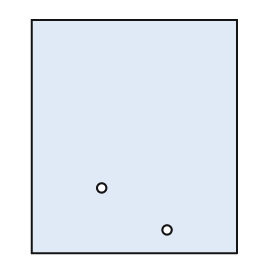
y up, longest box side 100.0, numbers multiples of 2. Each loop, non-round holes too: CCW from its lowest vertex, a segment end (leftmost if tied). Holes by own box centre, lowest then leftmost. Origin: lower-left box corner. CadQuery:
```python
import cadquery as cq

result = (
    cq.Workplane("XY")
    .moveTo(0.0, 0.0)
    .lineTo(88.0, 0.0)
    .lineTo(88.0, 100.0)
    .lineTo(0.0, 100.0)
    .close()
    .moveTo(58.0, 10.0)
    .circle(2.0)
    .moveTo(30.0, 28.0)
    .circle(2.0)
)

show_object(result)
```